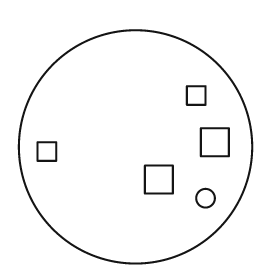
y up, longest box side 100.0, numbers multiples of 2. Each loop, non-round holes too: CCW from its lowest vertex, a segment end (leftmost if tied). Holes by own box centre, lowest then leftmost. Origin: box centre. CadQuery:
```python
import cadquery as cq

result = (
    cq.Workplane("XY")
    .moveTo(0.0, 0.0)
    .circle(50.0)
    .moveTo(30.0, -22.0)
    .circle(4.0)
    .moveTo(4.0, -20.0)
    .lineTo(16.0, -20.0)
    .lineTo(16.0, -8.0)
    .lineTo(4.0, -8.0)
    .close()
    .moveTo(-42.0, -6.0)
    .lineTo(-34.0, -6.0)
    .lineTo(-34.0, 2.0)
    .lineTo(-42.0, 2.0)
    .close()
    .moveTo(28.0, -4.0)
    .lineTo(40.0, -4.0)
    .lineTo(40.0, 8.0)
    .lineTo(28.0, 8.0)
    .close()
    .moveTo(22.0, 18.0)
    .lineTo(30.0, 18.0)
    .lineTo(30.0, 26.0)
    .lineTo(22.0, 26.0)
    .close()
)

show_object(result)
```